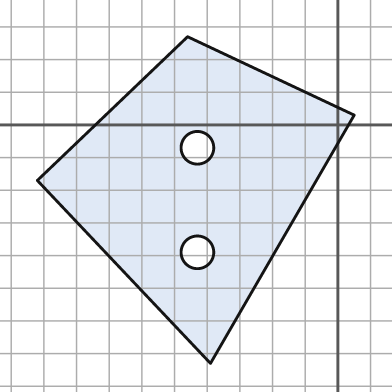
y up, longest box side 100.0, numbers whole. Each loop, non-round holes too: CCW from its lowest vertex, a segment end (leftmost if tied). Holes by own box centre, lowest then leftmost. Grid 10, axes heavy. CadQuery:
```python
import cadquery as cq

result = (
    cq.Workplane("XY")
    .moveTo(-39.0, -73.0)
    .lineTo(5.0, 3.0)
    .lineTo(-46.0, 27.0)
    .lineTo(-92.0, -17.0)
    .close()
    .moveTo(-43.0, -39.0)
    .circle(5.0)
    .moveTo(-43.0, -7.0)
    .circle(5.0)
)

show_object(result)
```